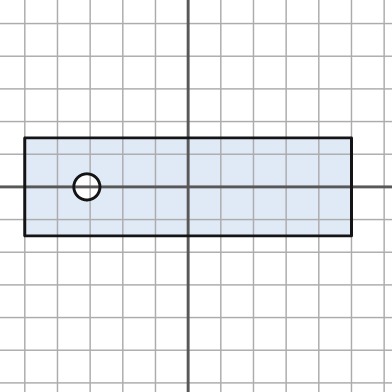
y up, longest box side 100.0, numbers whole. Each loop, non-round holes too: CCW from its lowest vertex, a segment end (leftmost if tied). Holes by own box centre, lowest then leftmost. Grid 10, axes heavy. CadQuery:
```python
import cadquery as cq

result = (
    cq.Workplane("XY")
    .moveTo(-50.0, -15.0)
    .lineTo(50.0, -15.0)
    .lineTo(50.0, 15.0)
    .lineTo(-50.0, 15.0)
    .close()
    .moveTo(-31.0, 0.0)
    .circle(4.0)
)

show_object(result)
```